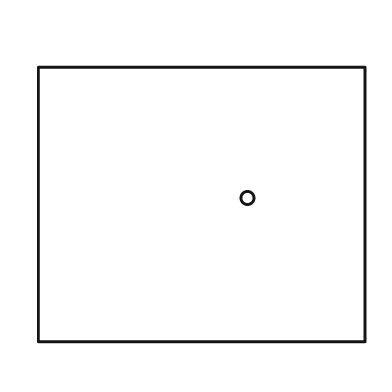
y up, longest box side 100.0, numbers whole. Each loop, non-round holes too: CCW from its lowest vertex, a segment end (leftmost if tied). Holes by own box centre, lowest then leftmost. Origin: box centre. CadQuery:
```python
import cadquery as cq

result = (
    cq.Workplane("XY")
    .moveTo(-50.0, -42.0)
    .lineTo(50.0, -42.0)
    .lineTo(50.0, 42.0)
    .lineTo(-50.0, 42.0)
    .close()
    .moveTo(14.0, 2.0)
    .circle(2.0)
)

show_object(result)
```